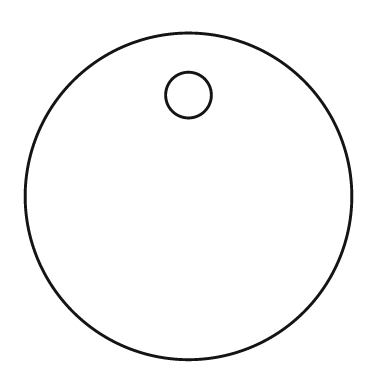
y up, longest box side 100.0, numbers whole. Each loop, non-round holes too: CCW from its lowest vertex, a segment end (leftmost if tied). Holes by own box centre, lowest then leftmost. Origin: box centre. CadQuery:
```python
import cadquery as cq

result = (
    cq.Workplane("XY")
    .moveTo(0.0, 0.0)
    .circle(50.0)
    .moveTo(0.0, 31.0)
    .circle(7.0)
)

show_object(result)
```